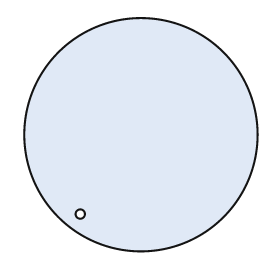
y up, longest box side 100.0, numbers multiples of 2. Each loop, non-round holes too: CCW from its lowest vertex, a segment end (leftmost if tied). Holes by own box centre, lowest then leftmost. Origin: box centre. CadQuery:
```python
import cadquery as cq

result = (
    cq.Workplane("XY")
    .moveTo(0.0, 0.0)
    .circle(50.0)
    .moveTo(-26.0, -34.0)
    .circle(2.0)
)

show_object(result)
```